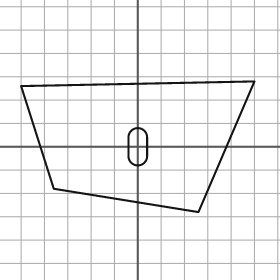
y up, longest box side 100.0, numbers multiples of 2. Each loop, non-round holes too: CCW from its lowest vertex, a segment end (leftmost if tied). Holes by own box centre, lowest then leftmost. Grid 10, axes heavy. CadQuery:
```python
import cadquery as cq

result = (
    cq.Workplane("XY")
    .moveTo(26.0, -28.0)
    .lineTo(50.0, 28.0)
    .lineTo(-50.0, 26.0)
    .lineTo(-36.0, -18.0)
    .close()
    .moveTo(-4.0, -4.0)
    .threePointArc((0.0, -8.0), (4.0, -4.0))
    .lineTo(4.0, 4.0)
    .threePointArc((0.0, 8.0), (-4.0, 4.0))
    .close()
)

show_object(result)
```